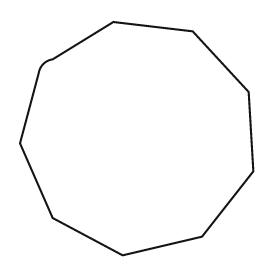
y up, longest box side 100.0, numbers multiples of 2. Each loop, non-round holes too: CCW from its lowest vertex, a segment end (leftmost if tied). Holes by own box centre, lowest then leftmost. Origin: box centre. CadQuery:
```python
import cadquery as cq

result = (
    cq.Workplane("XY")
    .moveTo(-6.0, -50.0)
    .lineTo(28.0, -42.0)
    .lineTo(50.0, -14.0)
    .lineTo(48.0, 20.0)
    .lineTo(24.0, 46.0)
    .lineTo(-10.0, 50.0)
    .lineTo(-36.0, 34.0)
    .threePointArc((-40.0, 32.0), (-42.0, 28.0))
    .lineTo(-50.0, -2.0)
    .lineTo(-36.0, -34.0)
    .close()
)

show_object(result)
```